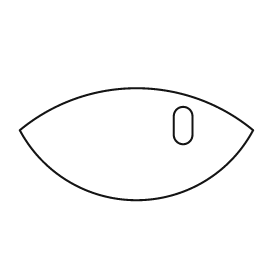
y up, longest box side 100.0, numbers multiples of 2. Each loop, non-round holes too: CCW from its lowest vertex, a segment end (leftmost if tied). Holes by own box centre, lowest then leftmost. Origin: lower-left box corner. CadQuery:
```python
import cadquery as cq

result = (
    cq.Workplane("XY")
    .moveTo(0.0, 30.0)
    .threePointArc((50.0, 0.0), (100.0, 30.0))
    .threePointArc((50.0, 48.0), (0.0, 30.0))
    .close()
    .moveTo(66.0, 28.0)
    .threePointArc((70.0, 24.0), (74.0, 28.0))
    .lineTo(74.0, 36.0)
    .threePointArc((70.0, 40.0), (66.0, 36.0))
    .close()
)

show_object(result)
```